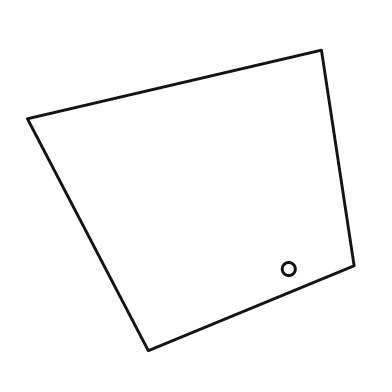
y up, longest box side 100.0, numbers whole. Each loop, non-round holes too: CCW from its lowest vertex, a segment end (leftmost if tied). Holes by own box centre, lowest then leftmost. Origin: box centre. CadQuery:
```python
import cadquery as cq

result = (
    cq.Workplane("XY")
    .moveTo(-13.0, -46.0)
    .lineTo(50.0, -20.0)
    .lineTo(40.0, 46.0)
    .lineTo(-50.0, 25.0)
    .close()
    .moveTo(30.0, -21.0)
    .circle(2.0)
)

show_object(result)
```